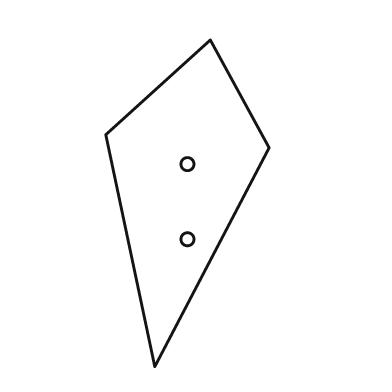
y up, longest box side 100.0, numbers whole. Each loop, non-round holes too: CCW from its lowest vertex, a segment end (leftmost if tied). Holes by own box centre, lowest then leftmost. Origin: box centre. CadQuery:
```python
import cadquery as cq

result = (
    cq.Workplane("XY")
    .moveTo(-10.0, -50.0)
    .lineTo(25.0, 17.0)
    .lineTo(7.0, 50.0)
    .lineTo(-25.0, 21.0)
    .close()
    .moveTo(0.0, -11.0)
    .circle(2.0)
    .moveTo(0.0, 12.0)
    .circle(2.0)
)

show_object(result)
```